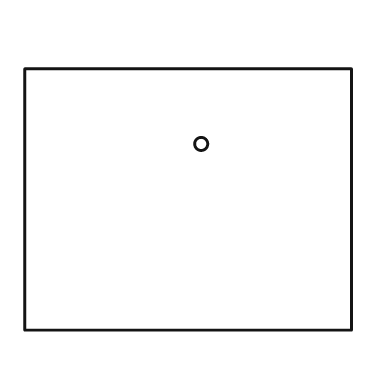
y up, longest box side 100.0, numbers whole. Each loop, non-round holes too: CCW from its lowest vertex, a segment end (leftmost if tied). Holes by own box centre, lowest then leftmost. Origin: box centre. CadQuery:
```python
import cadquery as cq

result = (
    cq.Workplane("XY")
    .moveTo(-50.0, -40.0)
    .lineTo(50.0, -40.0)
    .lineTo(50.0, 40.0)
    .lineTo(-50.0, 40.0)
    .close()
    .moveTo(4.0, 17.0)
    .circle(2.0)
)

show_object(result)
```